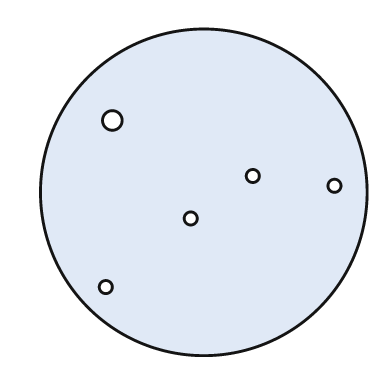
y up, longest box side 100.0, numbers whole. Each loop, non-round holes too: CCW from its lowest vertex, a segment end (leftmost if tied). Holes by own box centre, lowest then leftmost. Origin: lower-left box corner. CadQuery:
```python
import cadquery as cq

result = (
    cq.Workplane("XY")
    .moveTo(50.0, 50.0)
    .circle(50.0)
    .moveTo(20.0, 21.0)
    .circle(2.0)
    .moveTo(46.0, 42.0)
    .circle(2.0)
    .moveTo(90.0, 52.0)
    .circle(2.0)
    .moveTo(65.0, 55.0)
    .circle(2.0)
    .moveTo(22.0, 72.0)
    .circle(3.0)
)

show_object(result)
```